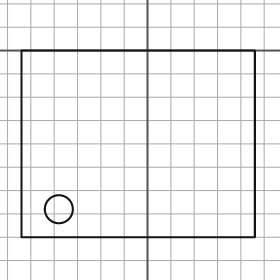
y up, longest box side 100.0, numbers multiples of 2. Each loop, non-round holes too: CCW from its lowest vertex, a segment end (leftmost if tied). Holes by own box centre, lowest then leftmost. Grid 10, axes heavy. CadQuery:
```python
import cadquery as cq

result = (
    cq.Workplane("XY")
    .moveTo(-54.0, -80.0)
    .lineTo(46.0, -80.0)
    .lineTo(46.0, 0.0)
    .lineTo(-54.0, 0.0)
    .close()
    .moveTo(-38.0, -68.0)
    .circle(6.0)
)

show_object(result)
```